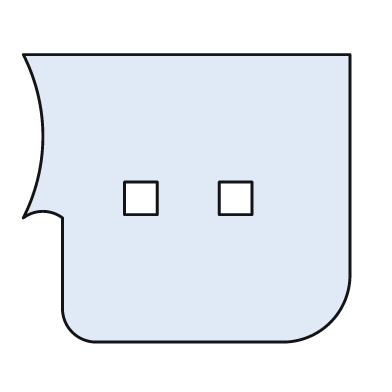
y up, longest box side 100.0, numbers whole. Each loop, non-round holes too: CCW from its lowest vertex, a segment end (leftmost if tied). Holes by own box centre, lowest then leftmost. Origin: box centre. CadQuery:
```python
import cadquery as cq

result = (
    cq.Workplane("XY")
    .moveTo(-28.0, -44.0)
    .lineTo(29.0, -44.0)
    .threePointArc((44.0, -38.0), (50.0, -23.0))
    .lineTo(50.0, 44.0)
    .lineTo(-50.0, 44.0)
    .threePointArc((-44.0, 19.0), (-50.0, -6.0))
    .threePointArc((-44.0, -4.0), (-38.0, -6.0))
    .lineTo(-38.0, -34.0)
    .threePointArc((-35.0, -41.0), (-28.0, -44.0))
    .close()
    .moveTo(-19.0, -5.0)
    .lineTo(-9.0, -5.0)
    .lineTo(-9.0, 5.0)
    .lineTo(-19.0, 5.0)
    .close()
    .moveTo(10.0, -5.0)
    .lineTo(20.0, -5.0)
    .lineTo(20.0, 5.0)
    .lineTo(10.0, 5.0)
    .close()
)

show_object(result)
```